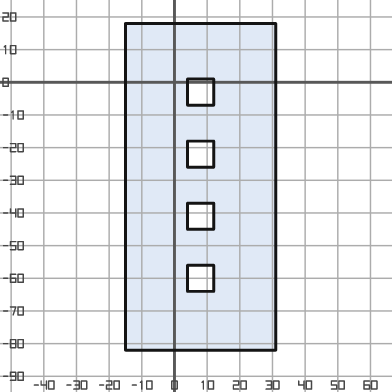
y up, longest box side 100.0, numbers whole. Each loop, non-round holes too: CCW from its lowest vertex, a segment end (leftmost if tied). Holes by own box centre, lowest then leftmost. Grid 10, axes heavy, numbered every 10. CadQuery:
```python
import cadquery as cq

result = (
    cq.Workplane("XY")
    .moveTo(-15.0, -82.0)
    .lineTo(31.0, -82.0)
    .lineTo(31.0, 18.0)
    .lineTo(-15.0, 18.0)
    .close()
    .moveTo(4.0, -64.0)
    .lineTo(12.0, -64.0)
    .lineTo(12.0, -56.0)
    .lineTo(4.0, -56.0)
    .close()
    .moveTo(4.0, -45.0)
    .lineTo(12.0, -45.0)
    .lineTo(12.0, -37.0)
    .lineTo(4.0, -37.0)
    .close()
    .moveTo(4.0, -26.0)
    .lineTo(12.0, -26.0)
    .lineTo(12.0, -18.0)
    .lineTo(4.0, -18.0)
    .close()
    .moveTo(4.0, -7.0)
    .lineTo(12.0, -7.0)
    .lineTo(12.0, 1.0)
    .lineTo(4.0, 1.0)
    .close()
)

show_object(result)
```